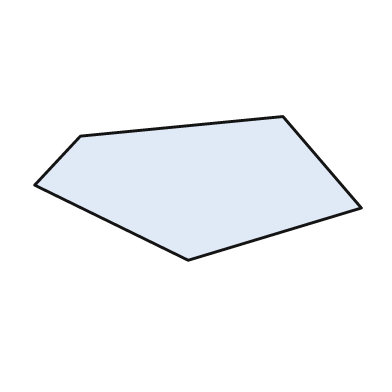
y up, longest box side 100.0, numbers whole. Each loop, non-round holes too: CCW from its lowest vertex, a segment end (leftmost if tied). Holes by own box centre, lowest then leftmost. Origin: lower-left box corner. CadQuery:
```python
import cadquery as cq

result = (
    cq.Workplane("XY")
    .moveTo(47.0, 0.0)
    .lineTo(100.0, 16.0)
    .lineTo(76.0, 44.0)
    .lineTo(14.0, 38.0)
    .lineTo(0.0, 23.0)
    .close()
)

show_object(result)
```